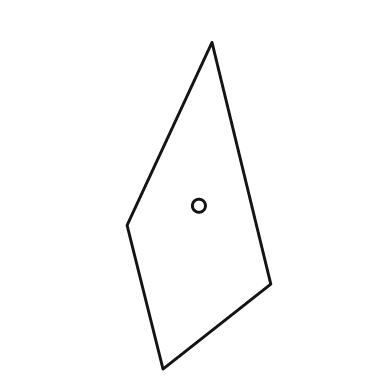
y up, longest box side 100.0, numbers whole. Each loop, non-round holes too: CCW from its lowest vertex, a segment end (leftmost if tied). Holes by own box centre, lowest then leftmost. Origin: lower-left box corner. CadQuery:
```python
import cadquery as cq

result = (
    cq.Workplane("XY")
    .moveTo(11.0, 0.0)
    .lineTo(44.0, 26.0)
    .lineTo(26.0, 100.0)
    .lineTo(0.0, 44.0)
    .close()
    .moveTo(22.0, 50.0)
    .circle(2.0)
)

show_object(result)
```